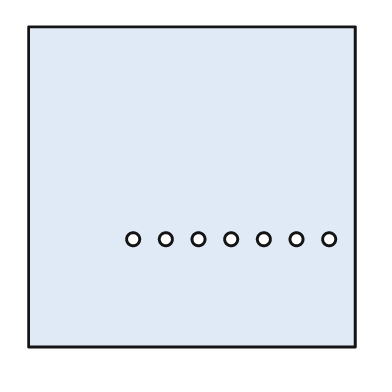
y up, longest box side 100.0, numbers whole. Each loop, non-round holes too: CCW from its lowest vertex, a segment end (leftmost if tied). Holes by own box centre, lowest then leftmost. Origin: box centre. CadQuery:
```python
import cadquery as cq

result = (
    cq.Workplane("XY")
    .moveTo(-50.0, -49.0)
    .lineTo(50.0, -49.0)
    .lineTo(50.0, 49.0)
    .lineTo(-50.0, 49.0)
    .close()
    .moveTo(-18.0, -16.0)
    .circle(2.0)
    .moveTo(-8.0, -16.0)
    .circle(2.0)
    .moveTo(2.0, -16.0)
    .circle(2.0)
    .moveTo(12.0, -16.0)
    .circle(2.0)
    .moveTo(22.0, -16.0)
    .circle(2.0)
    .moveTo(32.0, -16.0)
    .circle(2.0)
    .moveTo(42.0, -16.0)
    .circle(2.0)
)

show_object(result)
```